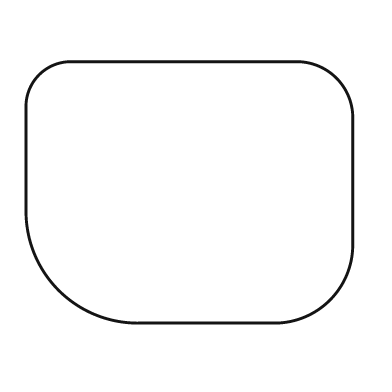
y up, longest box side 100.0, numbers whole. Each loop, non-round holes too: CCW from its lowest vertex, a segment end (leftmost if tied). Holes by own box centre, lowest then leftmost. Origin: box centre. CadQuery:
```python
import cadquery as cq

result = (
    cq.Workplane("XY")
    .moveTo(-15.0, -40.0)
    .lineTo(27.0, -40.0)
    .threePointArc((43.0, -33.0), (50.0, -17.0))
    .lineTo(50.0, 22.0)
    .threePointArc((45.0, 35.0), (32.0, 40.0))
    .lineTo(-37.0, 40.0)
    .threePointArc((-46.0, 36.0), (-50.0, 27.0))
    .lineTo(-50.0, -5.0)
    .threePointArc((-40.0, -30.0), (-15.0, -40.0))
    .close()
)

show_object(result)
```